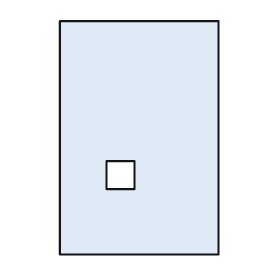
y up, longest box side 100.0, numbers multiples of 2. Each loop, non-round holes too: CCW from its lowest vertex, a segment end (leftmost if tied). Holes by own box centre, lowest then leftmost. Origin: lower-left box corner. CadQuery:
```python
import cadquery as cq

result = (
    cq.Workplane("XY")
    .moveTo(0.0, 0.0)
    .lineTo(68.0, 0.0)
    .lineTo(68.0, 100.0)
    .lineTo(0.0, 100.0)
    .close()
    .moveTo(20.0, 28.0)
    .lineTo(32.0, 28.0)
    .lineTo(32.0, 40.0)
    .lineTo(20.0, 40.0)
    .close()
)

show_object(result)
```